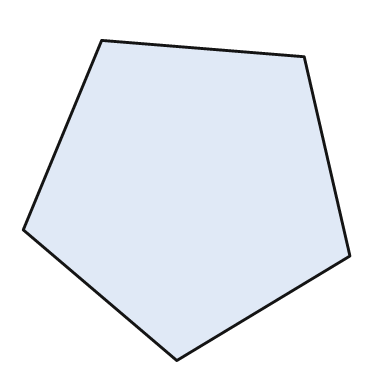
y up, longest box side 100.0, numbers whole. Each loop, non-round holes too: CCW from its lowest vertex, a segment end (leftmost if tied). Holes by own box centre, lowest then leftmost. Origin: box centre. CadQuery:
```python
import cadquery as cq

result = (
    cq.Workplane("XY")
    .moveTo(-3.0, -49.0)
    .lineTo(50.0, -17.0)
    .lineTo(36.0, 44.0)
    .lineTo(-26.0, 49.0)
    .lineTo(-50.0, -9.0)
    .close()
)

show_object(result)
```